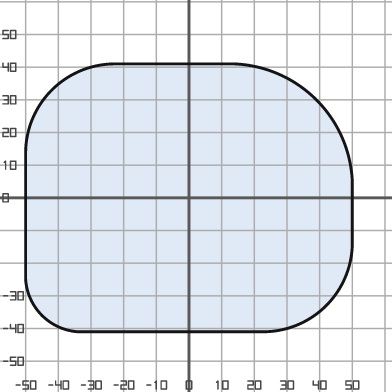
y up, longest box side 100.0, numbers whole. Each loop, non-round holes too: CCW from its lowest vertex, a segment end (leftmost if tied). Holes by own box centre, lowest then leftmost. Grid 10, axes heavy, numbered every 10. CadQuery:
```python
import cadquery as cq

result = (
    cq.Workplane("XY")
    .moveTo(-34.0, -41.0)
    .lineTo(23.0, -41.0)
    .threePointArc((42.0, -33.0), (50.0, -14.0))
    .lineTo(50.0, 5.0)
    .threePointArc((39.0, 30.0), (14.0, 41.0))
    .lineTo(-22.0, 41.0)
    .threePointArc((-42.0, 33.0), (-50.0, 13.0))
    .lineTo(-50.0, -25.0)
    .threePointArc((-45.0, -36.0), (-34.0, -41.0))
    .close()
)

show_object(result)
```